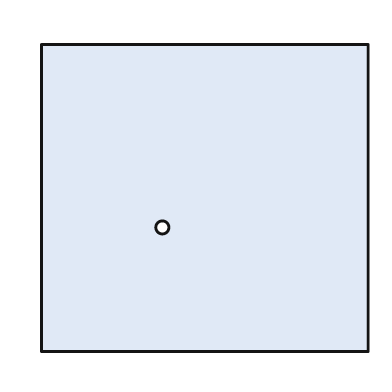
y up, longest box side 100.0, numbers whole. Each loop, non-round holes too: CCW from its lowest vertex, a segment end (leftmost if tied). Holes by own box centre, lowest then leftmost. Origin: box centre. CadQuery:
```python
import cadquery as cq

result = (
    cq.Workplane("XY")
    .moveTo(-50.0, -47.0)
    .lineTo(50.0, -47.0)
    .lineTo(50.0, 47.0)
    .lineTo(-50.0, 47.0)
    .close()
    .moveTo(-13.0, -9.0)
    .circle(2.0)
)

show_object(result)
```